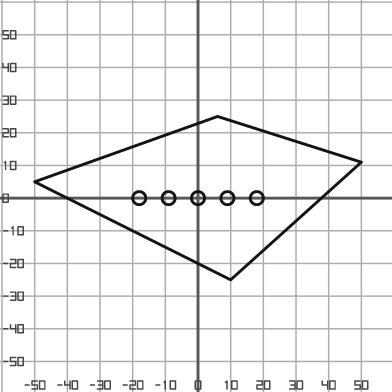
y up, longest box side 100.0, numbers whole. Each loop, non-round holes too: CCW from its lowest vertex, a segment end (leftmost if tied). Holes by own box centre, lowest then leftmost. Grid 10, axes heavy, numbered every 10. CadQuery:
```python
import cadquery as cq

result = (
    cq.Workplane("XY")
    .moveTo(10.0, -25.0)
    .lineTo(50.0, 11.0)
    .lineTo(6.0, 25.0)
    .lineTo(-50.0, 5.0)
    .close()
    .moveTo(-18.0, 0.0)
    .circle(2.0)
    .moveTo(-9.0, 0.0)
    .circle(2.0)
    .moveTo(0.0, 0.0)
    .circle(2.0)
    .moveTo(9.0, 0.0)
    .circle(2.0)
    .moveTo(18.0, 0.0)
    .circle(2.0)
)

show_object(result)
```